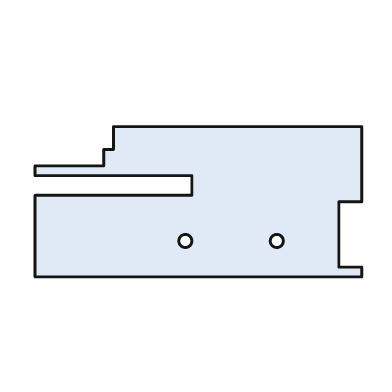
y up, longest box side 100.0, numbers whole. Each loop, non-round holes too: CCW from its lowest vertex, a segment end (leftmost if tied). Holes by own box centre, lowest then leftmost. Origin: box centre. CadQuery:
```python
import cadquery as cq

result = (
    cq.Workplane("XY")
    .moveTo(-50.0, -23.0)
    .lineTo(50.0, -23.0)
    .lineTo(50.0, -20.0)
    .lineTo(43.0, -20.0)
    .lineTo(43.0, 0.0)
    .lineTo(50.0, 0.0)
    .lineTo(50.0, 23.0)
    .lineTo(-26.0, 23.0)
    .lineTo(-26.0, 16.0)
    .lineTo(-29.0, 16.0)
    .lineTo(-29.0, 11.0)
    .lineTo(-50.0, 11.0)
    .lineTo(-50.0, 8.0)
    .lineTo(-2.0, 8.0)
    .lineTo(-2.0, 2.0)
    .lineTo(-50.0, 2.0)
    .close()
    .moveTo(-4.0, -12.0)
    .circle(2.0)
    .moveTo(24.0, -12.0)
    .circle(2.0)
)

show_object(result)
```